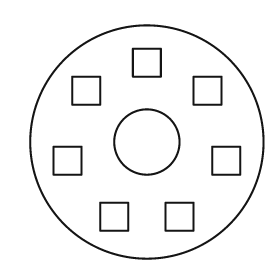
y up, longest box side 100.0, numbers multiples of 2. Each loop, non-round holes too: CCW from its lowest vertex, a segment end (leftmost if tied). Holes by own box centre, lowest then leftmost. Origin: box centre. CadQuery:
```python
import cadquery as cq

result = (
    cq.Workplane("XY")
    .moveTo(0.0, 0.0)
    .circle(50.0)
    .moveTo(-20.0, -38.0)
    .lineTo(-8.0, -38.0)
    .lineTo(-8.0, -26.0)
    .lineTo(-20.0, -26.0)
    .close()
    .moveTo(8.0, -38.0)
    .lineTo(20.0, -38.0)
    .lineTo(20.0, -26.0)
    .lineTo(8.0, -26.0)
    .close()
    .moveTo(-40.0, -14.0)
    .lineTo(-28.0, -14.0)
    .lineTo(-28.0, -2.0)
    .lineTo(-40.0, -2.0)
    .close()
    .moveTo(28.0, -14.0)
    .lineTo(40.0, -14.0)
    .lineTo(40.0, -2.0)
    .lineTo(28.0, -2.0)
    .close()
    .moveTo(0.0, 0.0)
    .circle(14.0)
    .moveTo(-32.0, 16.0)
    .lineTo(-20.0, 16.0)
    .lineTo(-20.0, 28.0)
    .lineTo(-32.0, 28.0)
    .close()
    .moveTo(20.0, 16.0)
    .lineTo(32.0, 16.0)
    .lineTo(32.0, 28.0)
    .lineTo(20.0, 28.0)
    .close()
    .moveTo(-6.0, 28.0)
    .lineTo(6.0, 28.0)
    .lineTo(6.0, 40.0)
    .lineTo(-6.0, 40.0)
    .close()
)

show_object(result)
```